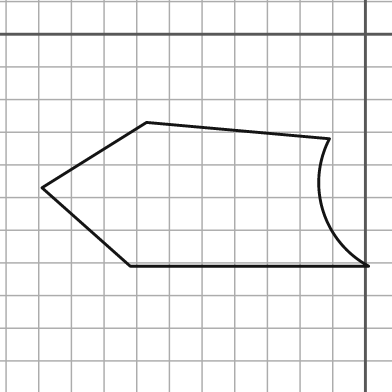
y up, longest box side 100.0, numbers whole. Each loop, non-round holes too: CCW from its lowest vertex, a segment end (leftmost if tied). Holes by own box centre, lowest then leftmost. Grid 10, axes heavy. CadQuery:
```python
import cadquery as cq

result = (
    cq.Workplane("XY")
    .moveTo(-72.0, -71.0)
    .lineTo(1.0, -71.0)
    .threePointArc((-13.0, -54.0), (-11.0, -32.0))
    .lineTo(-67.0, -27.0)
    .lineTo(-99.0, -47.0)
    .close()
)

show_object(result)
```